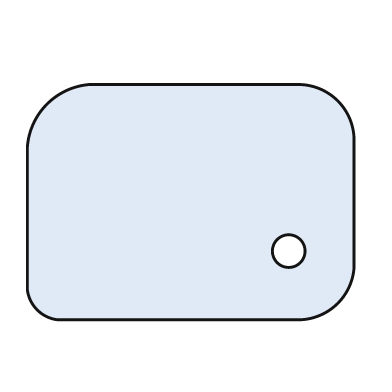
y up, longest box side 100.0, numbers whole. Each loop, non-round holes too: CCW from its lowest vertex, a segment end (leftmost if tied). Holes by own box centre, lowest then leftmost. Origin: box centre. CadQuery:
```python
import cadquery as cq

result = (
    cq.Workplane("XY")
    .moveTo(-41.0, -36.0)
    .lineTo(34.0, -36.0)
    .threePointArc((45.0, -31.0), (50.0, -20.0))
    .lineTo(50.0, 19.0)
    .threePointArc((45.0, 31.0), (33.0, 36.0))
    .lineTo(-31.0, 36.0)
    .threePointArc((-44.0, 30.0), (-50.0, 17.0))
    .lineTo(-50.0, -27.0)
    .threePointArc((-47.0, -33.0), (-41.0, -36.0))
    .close()
    .moveTo(30.0, -15.0)
    .circle(5.0)
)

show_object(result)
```